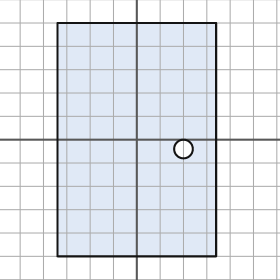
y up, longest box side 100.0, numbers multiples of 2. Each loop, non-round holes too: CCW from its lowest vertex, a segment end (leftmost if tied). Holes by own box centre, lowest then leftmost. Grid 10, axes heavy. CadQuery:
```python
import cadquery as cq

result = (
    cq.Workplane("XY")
    .moveTo(-34.0, -50.0)
    .lineTo(34.0, -50.0)
    .lineTo(34.0, 50.0)
    .lineTo(-34.0, 50.0)
    .close()
    .moveTo(20.0, -4.0)
    .circle(4.0)
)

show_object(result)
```